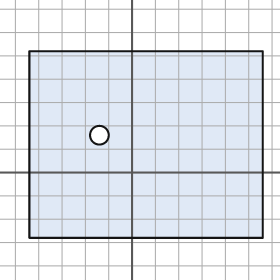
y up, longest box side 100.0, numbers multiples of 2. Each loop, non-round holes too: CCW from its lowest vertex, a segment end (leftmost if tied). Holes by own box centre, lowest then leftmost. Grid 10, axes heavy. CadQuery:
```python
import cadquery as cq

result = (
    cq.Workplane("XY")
    .moveTo(-44.0, -28.0)
    .lineTo(56.0, -28.0)
    .lineTo(56.0, 52.0)
    .lineTo(-44.0, 52.0)
    .close()
    .moveTo(-14.0, 16.0)
    .circle(4.0)
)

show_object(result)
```